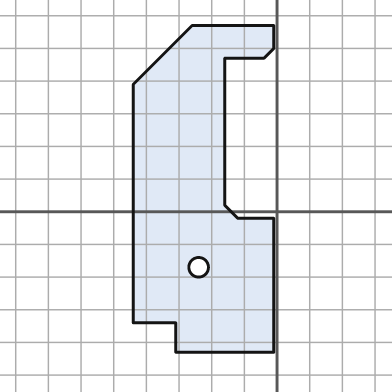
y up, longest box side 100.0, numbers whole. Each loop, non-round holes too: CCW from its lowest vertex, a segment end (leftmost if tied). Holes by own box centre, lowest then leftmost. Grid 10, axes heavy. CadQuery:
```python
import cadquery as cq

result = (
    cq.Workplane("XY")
    .moveTo(-31.0, -43.0)
    .lineTo(-1.0, -43.0)
    .lineTo(-1.0, -2.0)
    .lineTo(-12.0, -2.0)
    .lineTo(-16.0, 2.0)
    .lineTo(-16.0, 47.0)
    .lineTo(-4.0, 47.0)
    .lineTo(-1.0, 50.0)
    .lineTo(-1.0, 57.0)
    .lineTo(-26.0, 57.0)
    .lineTo(-44.0, 39.0)
    .lineTo(-44.0, -34.0)
    .lineTo(-31.0, -34.0)
    .close()
    .moveTo(-24.0, -17.0)
    .circle(3.0)
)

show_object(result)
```